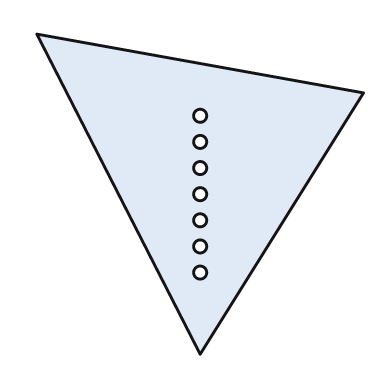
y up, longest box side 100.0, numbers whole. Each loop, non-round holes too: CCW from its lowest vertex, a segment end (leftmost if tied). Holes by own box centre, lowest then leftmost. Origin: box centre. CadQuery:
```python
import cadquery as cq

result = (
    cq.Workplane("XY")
    .moveTo(0.0, -49.0)
    .lineTo(50.0, 31.0)
    .lineTo(-50.0, 49.0)
    .close()
    .moveTo(0.0, -24.0)
    .circle(2.0)
    .moveTo(0.0, -16.0)
    .circle(2.0)
    .moveTo(0.0, -8.0)
    .circle(2.0)
    .moveTo(0.0, 0.0)
    .circle(2.0)
    .moveTo(0.0, 8.0)
    .circle(2.0)
    .moveTo(0.0, 16.0)
    .circle(2.0)
    .moveTo(0.0, 24.0)
    .circle(2.0)
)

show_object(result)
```